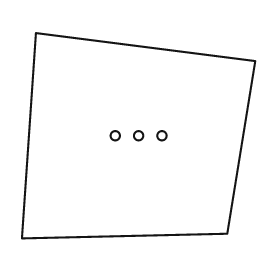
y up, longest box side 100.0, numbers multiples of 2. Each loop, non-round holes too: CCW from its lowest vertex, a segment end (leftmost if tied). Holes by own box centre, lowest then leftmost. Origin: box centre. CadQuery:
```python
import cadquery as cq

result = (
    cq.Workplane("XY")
    .moveTo(-50.0, -44.0)
    .lineTo(38.0, -42.0)
    .lineTo(50.0, 32.0)
    .lineTo(-44.0, 44.0)
    .close()
    .moveTo(-10.0, 0.0)
    .circle(2.0)
    .moveTo(0.0, 0.0)
    .circle(2.0)
    .moveTo(10.0, 0.0)
    .circle(2.0)
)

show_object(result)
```